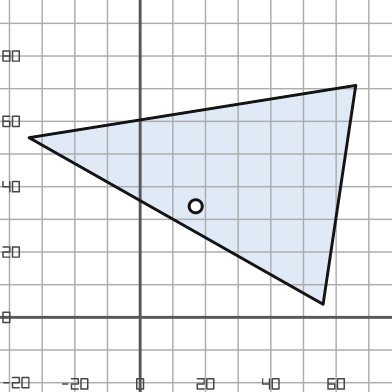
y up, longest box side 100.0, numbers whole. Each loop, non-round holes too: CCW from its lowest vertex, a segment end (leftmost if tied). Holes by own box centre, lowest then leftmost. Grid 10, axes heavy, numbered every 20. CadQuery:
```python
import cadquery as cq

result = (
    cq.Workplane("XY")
    .moveTo(56.0, 4.0)
    .lineTo(66.0, 71.0)
    .lineTo(-34.0, 55.0)
    .close()
    .moveTo(17.0, 34.0)
    .circle(2.0)
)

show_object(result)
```